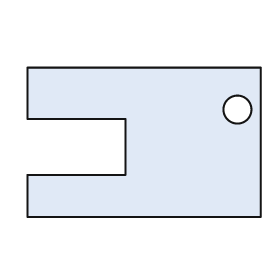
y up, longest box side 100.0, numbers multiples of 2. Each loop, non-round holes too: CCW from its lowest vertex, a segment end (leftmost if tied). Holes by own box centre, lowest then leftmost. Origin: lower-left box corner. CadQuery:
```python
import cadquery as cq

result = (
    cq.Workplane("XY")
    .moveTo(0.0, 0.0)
    .lineTo(100.0, 0.0)
    .lineTo(100.0, 64.0)
    .lineTo(0.0, 64.0)
    .lineTo(0.0, 42.0)
    .lineTo(42.0, 42.0)
    .lineTo(42.0, 18.0)
    .lineTo(0.0, 18.0)
    .close()
    .moveTo(90.0, 46.0)
    .circle(6.0)
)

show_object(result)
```